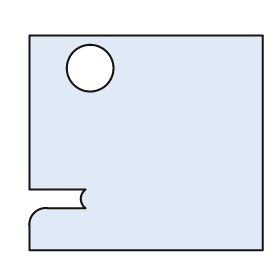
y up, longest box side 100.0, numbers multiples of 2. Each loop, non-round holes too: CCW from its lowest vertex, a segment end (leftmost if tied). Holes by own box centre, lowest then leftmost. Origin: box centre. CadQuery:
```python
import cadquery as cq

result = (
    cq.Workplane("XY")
    .moveTo(-50.0, -46.0)
    .lineTo(50.0, -46.0)
    .lineTo(50.0, 46.0)
    .lineTo(-50.0, 46.0)
    .lineTo(-50.0, -20.0)
    .lineTo(-26.0, -20.0)
    .threePointArc((-28.0, -24.0), (-26.0, -28.0))
    .lineTo(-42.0, -28.0)
    .threePointArc((-48.0, -30.0), (-50.0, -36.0))
    .close()
    .moveTo(-24.0, 32.0)
    .circle(10.0)
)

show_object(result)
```